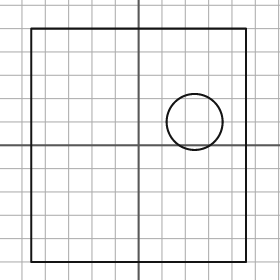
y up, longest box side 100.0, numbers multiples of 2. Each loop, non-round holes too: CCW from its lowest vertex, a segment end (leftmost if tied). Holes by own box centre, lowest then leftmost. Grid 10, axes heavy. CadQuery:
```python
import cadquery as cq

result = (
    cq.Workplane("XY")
    .moveTo(-46.0, -50.0)
    .lineTo(46.0, -50.0)
    .lineTo(46.0, 50.0)
    .lineTo(-46.0, 50.0)
    .close()
    .moveTo(24.0, 10.0)
    .circle(12.0)
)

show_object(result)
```